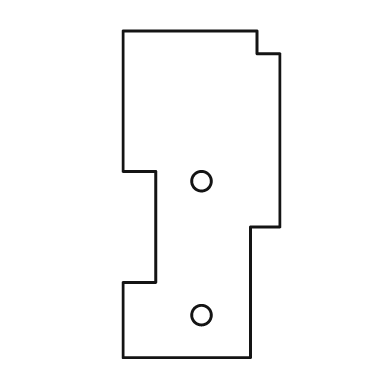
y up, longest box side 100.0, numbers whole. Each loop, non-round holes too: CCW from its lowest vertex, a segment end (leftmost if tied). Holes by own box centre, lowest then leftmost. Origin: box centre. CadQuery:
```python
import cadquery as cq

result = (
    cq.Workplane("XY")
    .moveTo(-24.0, -50.0)
    .lineTo(15.0, -50.0)
    .lineTo(15.0, -10.0)
    .lineTo(24.0, -10.0)
    .lineTo(24.0, 43.0)
    .lineTo(17.0, 43.0)
    .lineTo(17.0, 50.0)
    .lineTo(-24.0, 50.0)
    .lineTo(-24.0, 7.0)
    .lineTo(-14.0, 7.0)
    .lineTo(-14.0, -27.0)
    .lineTo(-24.0, -27.0)
    .close()
    .moveTo(0.0, -37.0)
    .circle(3.0)
    .moveTo(0.0, 4.0)
    .circle(3.0)
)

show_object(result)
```